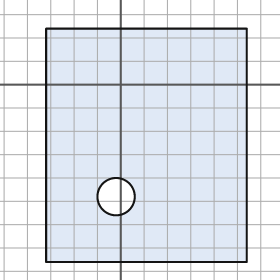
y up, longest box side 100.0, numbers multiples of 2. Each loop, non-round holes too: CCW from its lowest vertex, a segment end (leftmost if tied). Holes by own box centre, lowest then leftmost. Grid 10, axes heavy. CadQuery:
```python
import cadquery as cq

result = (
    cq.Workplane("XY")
    .moveTo(-32.0, -76.0)
    .lineTo(54.0, -76.0)
    .lineTo(54.0, 24.0)
    .lineTo(-32.0, 24.0)
    .close()
    .moveTo(-2.0, -48.0)
    .circle(8.0)
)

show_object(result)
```